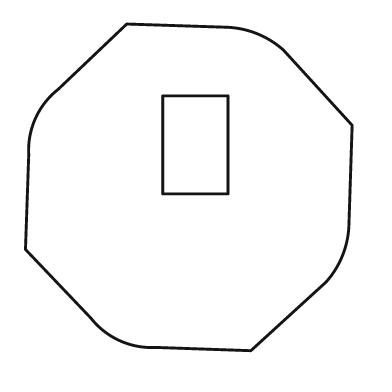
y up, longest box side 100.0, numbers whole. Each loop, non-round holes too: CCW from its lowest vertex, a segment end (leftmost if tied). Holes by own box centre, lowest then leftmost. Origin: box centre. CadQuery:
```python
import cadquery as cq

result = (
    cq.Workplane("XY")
    .moveTo(19.0, -50.0)
    .lineTo(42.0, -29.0)
    .threePointArc((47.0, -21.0), (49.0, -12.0))
    .lineTo(50.0, 19.0)
    .lineTo(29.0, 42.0)
    .threePointArc((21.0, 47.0), (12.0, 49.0))
    .lineTo(-19.0, 50.0)
    .lineTo(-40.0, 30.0)
    .threePointArc((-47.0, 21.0), (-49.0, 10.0))
    .lineTo(-50.0, -19.0)
    .lineTo(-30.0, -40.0)
    .threePointArc((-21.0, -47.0), (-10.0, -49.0))
    .close()
    .moveTo(-8.0, -2.0)
    .lineTo(12.0, -2.0)
    .lineTo(12.0, 28.0)
    .lineTo(-8.0, 28.0)
    .close()
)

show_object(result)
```